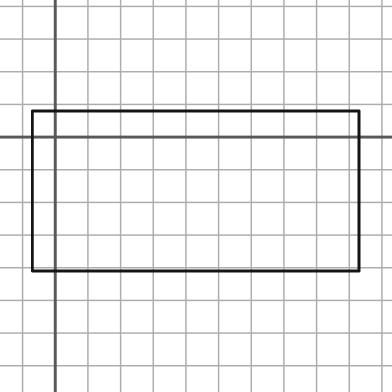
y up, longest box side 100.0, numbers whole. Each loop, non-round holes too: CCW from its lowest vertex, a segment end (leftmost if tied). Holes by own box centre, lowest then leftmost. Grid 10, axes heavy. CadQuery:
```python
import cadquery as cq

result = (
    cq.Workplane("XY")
    .moveTo(-7.0, -41.0)
    .lineTo(93.0, -41.0)
    .lineTo(93.0, 8.0)
    .lineTo(-7.0, 8.0)
    .close()
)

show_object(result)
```